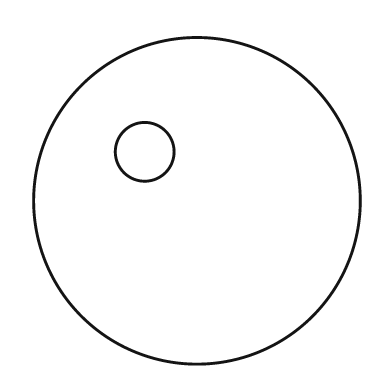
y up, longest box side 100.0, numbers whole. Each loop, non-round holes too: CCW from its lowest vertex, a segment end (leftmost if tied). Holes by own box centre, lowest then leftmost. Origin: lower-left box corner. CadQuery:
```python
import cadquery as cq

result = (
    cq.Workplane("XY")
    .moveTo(50.0, 50.0)
    .circle(50.0)
    .moveTo(34.0, 65.0)
    .circle(9.0)
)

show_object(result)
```